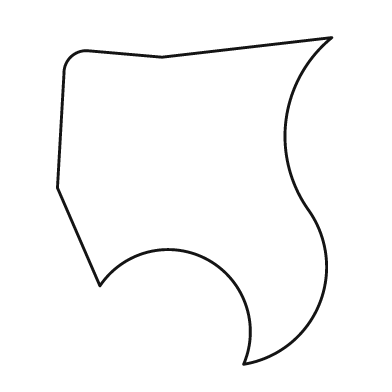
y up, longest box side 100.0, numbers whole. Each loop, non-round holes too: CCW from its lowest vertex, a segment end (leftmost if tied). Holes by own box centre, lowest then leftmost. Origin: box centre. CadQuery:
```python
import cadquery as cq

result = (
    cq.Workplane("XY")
    .moveTo(15.0, -50.0)
    .threePointArc((38.0, -32.0), (35.0, -3.0))
    .threePointArc((28.0, 25.0), (42.0, 50.0))
    .lineTo(-10.0, 44.0)
    .lineTo(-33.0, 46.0)
    .threePointArc((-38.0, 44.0), (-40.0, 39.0))
    .lineTo(-42.0, 4.0)
    .lineTo(-29.0, -26.0)
    .threePointArc((4.0, -18.0), (15.0, -50.0))
    .close()
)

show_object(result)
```